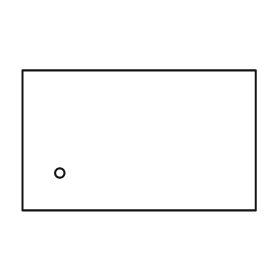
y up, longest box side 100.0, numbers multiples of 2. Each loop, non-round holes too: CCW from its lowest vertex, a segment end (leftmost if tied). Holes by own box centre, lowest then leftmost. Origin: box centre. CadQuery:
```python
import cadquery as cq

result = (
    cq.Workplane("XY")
    .moveTo(-50.0, -30.0)
    .lineTo(50.0, -30.0)
    .lineTo(50.0, 30.0)
    .lineTo(-50.0, 30.0)
    .close()
    .moveTo(-34.0, -14.0)
    .circle(2.0)
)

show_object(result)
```